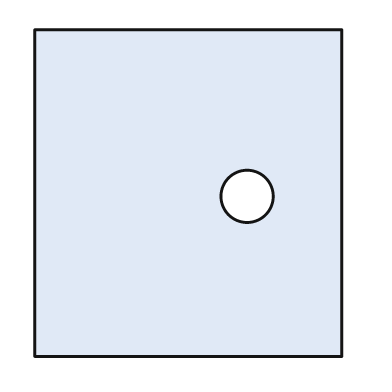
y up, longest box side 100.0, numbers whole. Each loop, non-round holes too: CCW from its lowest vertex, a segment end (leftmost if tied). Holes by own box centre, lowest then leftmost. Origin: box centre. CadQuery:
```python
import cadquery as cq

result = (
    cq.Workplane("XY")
    .moveTo(-47.0, -50.0)
    .lineTo(47.0, -50.0)
    .lineTo(47.0, 50.0)
    .lineTo(-47.0, 50.0)
    .close()
    .moveTo(18.0, -1.0)
    .circle(8.0)
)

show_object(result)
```